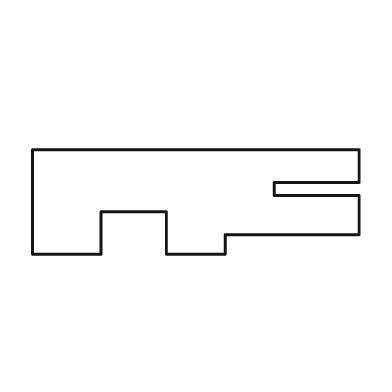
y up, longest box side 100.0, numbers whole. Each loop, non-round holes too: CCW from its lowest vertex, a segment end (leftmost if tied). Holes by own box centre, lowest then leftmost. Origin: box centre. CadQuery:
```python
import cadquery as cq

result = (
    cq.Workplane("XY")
    .moveTo(-50.0, -16.0)
    .lineTo(-29.0, -16.0)
    .lineTo(-29.0, -3.0)
    .lineTo(-9.0, -3.0)
    .lineTo(-9.0, -16.0)
    .lineTo(9.0, -16.0)
    .lineTo(9.0, -10.0)
    .lineTo(50.0, -10.0)
    .lineTo(50.0, 2.0)
    .lineTo(24.0, 2.0)
    .lineTo(24.0, 6.0)
    .lineTo(50.0, 6.0)
    .lineTo(50.0, 16.0)
    .lineTo(-50.0, 16.0)
    .close()
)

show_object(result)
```